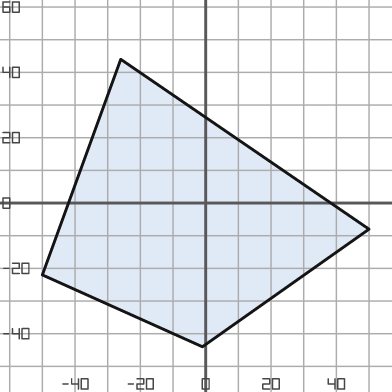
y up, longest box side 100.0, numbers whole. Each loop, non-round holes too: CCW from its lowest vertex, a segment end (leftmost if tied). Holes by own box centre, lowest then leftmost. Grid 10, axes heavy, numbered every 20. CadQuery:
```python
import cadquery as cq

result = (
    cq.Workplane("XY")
    .moveTo(-1.0, -44.0)
    .lineTo(50.0, -8.0)
    .lineTo(-26.0, 44.0)
    .lineTo(-50.0, -22.0)
    .close()
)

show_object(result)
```